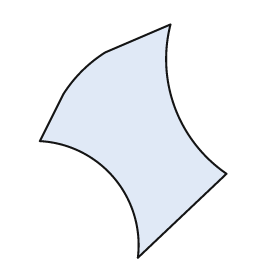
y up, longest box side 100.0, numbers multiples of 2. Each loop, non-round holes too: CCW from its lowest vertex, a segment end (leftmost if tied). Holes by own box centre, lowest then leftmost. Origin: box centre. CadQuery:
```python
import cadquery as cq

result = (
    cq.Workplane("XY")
    .moveTo(2.0, -50.0)
    .lineTo(40.0, -14.0)
    .threePointArc((18.0, 14.0), (16.0, 50.0))
    .lineTo(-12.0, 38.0)
    .threePointArc((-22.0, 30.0), (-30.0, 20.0))
    .lineTo(-40.0, 0.0)
    .threePointArc((-8.0, -16.0), (2.0, -50.0))
    .close()
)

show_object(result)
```